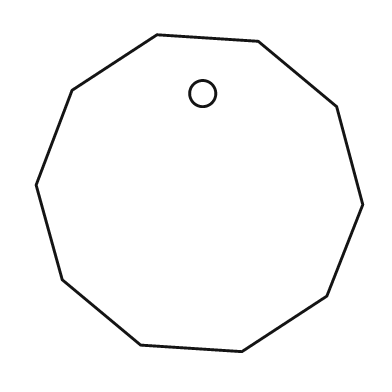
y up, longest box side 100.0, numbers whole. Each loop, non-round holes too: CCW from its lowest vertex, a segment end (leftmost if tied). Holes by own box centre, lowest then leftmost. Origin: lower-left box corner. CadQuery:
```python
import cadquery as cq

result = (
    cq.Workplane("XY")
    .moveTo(63.0, 0.0)
    .lineTo(89.0, 17.0)
    .lineTo(100.0, 45.0)
    .lineTo(92.0, 75.0)
    .lineTo(68.0, 95.0)
    .lineTo(37.0, 97.0)
    .lineTo(11.0, 80.0)
    .lineTo(0.0, 51.0)
    .lineTo(8.0, 22.0)
    .lineTo(32.0, 2.0)
    .close()
    .moveTo(51.0, 79.0)
    .circle(4.0)
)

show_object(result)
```